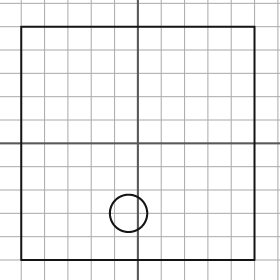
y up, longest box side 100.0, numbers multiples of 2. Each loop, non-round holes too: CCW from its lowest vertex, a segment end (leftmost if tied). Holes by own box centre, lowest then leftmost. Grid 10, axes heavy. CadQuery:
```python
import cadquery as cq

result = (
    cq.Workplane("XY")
    .moveTo(-50.0, -50.0)
    .lineTo(50.0, -50.0)
    .lineTo(50.0, 50.0)
    .lineTo(-50.0, 50.0)
    .close()
    .moveTo(-4.0, -30.0)
    .circle(8.0)
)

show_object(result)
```